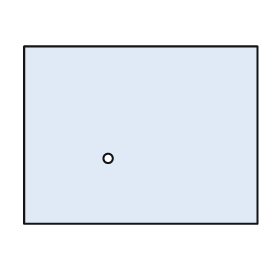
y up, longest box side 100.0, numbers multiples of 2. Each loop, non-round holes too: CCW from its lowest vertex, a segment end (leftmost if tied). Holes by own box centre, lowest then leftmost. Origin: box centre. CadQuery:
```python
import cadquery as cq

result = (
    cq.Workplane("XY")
    .moveTo(-50.0, -38.0)
    .lineTo(50.0, -38.0)
    .lineTo(50.0, 38.0)
    .lineTo(-50.0, 38.0)
    .close()
    .moveTo(-14.0, -10.0)
    .circle(2.0)
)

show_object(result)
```